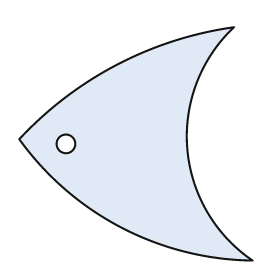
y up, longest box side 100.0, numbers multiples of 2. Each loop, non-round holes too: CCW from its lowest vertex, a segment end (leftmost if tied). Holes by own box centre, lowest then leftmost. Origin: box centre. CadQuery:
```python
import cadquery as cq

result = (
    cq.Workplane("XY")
    .moveTo(50.0, -50.0)
    .threePointArc((22.0, -2.0), (42.0, 50.0))
    .threePointArc((-8.0, 34.0), (-50.0, 2.0))
    .threePointArc((-6.0, -36.0), (50.0, -50.0))
    .close()
    .moveTo(-30.0, 0.0)
    .circle(4.0)
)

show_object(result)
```